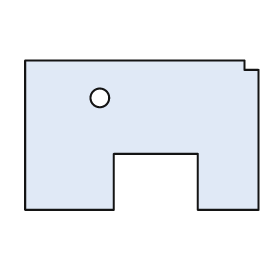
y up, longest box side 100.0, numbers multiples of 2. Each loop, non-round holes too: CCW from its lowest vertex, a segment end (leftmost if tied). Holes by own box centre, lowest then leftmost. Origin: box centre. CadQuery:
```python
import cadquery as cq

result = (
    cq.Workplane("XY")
    .moveTo(-50.0, -32.0)
    .lineTo(-12.0, -32.0)
    .lineTo(-12.0, -8.0)
    .lineTo(24.0, -8.0)
    .lineTo(24.0, -32.0)
    .lineTo(50.0, -32.0)
    .lineTo(50.0, 28.0)
    .lineTo(44.0, 28.0)
    .lineTo(44.0, 32.0)
    .lineTo(-50.0, 32.0)
    .close()
    .moveTo(-18.0, 16.0)
    .circle(4.0)
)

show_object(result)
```